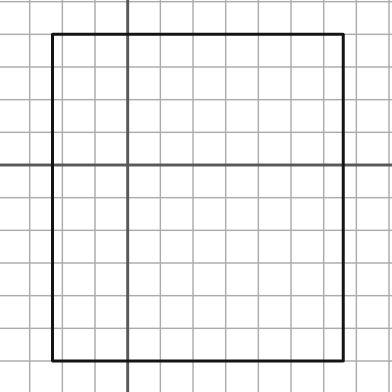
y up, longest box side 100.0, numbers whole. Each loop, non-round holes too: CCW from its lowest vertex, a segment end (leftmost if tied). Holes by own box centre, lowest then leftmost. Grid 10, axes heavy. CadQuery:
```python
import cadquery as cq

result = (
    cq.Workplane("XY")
    .moveTo(-23.0, -60.0)
    .lineTo(66.0, -60.0)
    .lineTo(66.0, 40.0)
    .lineTo(-23.0, 40.0)
    .close()
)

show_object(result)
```